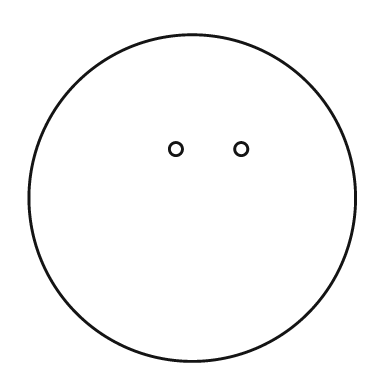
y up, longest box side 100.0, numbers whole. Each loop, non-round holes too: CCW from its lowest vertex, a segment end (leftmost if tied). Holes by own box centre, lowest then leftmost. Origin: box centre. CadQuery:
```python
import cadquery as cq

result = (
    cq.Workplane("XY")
    .moveTo(0.0, 0.0)
    .circle(50.0)
    .moveTo(-5.0, 15.0)
    .circle(2.0)
    .moveTo(15.0, 15.0)
    .circle(2.0)
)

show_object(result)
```